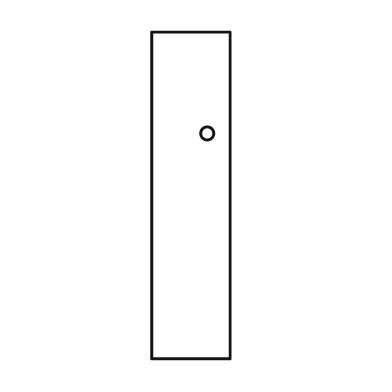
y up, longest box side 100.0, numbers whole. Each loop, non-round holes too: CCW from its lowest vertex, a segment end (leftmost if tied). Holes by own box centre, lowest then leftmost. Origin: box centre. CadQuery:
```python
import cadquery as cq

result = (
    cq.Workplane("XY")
    .moveTo(-12.0, -50.0)
    .lineTo(12.0, -50.0)
    .lineTo(12.0, 50.0)
    .lineTo(-12.0, 50.0)
    .close()
    .moveTo(5.0, 19.0)
    .circle(2.0)
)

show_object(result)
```